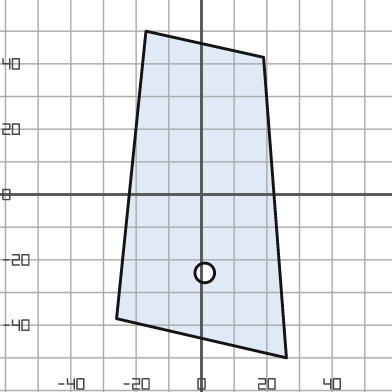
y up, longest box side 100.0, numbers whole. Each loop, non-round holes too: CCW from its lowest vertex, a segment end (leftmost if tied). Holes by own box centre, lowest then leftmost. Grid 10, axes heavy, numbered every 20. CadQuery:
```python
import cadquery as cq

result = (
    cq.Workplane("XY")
    .moveTo(26.0, -50.0)
    .lineTo(19.0, 42.0)
    .lineTo(-17.0, 50.0)
    .lineTo(-26.0, -38.0)
    .close()
    .moveTo(1.0, -24.0)
    .circle(3.0)
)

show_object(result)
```